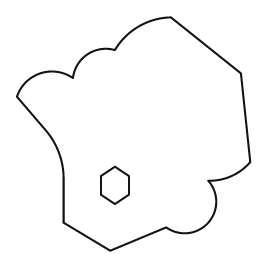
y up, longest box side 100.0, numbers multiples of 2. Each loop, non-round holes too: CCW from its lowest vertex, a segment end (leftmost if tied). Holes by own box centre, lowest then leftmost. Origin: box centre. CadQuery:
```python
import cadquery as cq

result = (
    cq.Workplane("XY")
    .moveTo(-10.0, -50.0)
    .lineTo(14.0, -40.0)
    .threePointArc((32.0, -38.0), (32.0, -20.0))
    .threePointArc((42.0, -18.0), (50.0, -12.0))
    .lineTo(46.0, 26.0)
    .lineTo(16.0, 50.0)
    .threePointArc((2.0, 46.0), (-8.0, 36.0))
    .threePointArc((-20.0, 34.0), (-26.0, 24.0))
    .threePointArc((-40.0, 26.0), (-50.0, 16.0))
    .lineTo(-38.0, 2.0)
    .threePointArc((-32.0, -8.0), (-30.0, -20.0))
    .lineTo(-30.0, -38.0)
    .close()
    .moveTo(-8.0, -30.0)
    .lineTo(-2.0, -26.0)
    .lineTo(-2.0, -18.0)
    .lineTo(-8.0, -14.0)
    .lineTo(-14.0, -18.0)
    .lineTo(-14.0, -26.0)
    .close()
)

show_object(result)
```